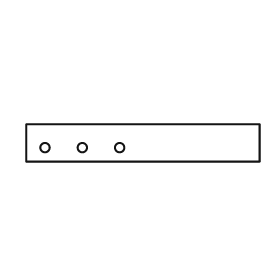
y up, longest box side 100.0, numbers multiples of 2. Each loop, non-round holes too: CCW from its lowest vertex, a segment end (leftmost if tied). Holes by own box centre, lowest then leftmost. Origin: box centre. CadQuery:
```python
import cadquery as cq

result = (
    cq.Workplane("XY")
    .moveTo(-50.0, -8.0)
    .lineTo(50.0, -8.0)
    .lineTo(50.0, 8.0)
    .lineTo(-50.0, 8.0)
    .close()
    .moveTo(-42.0, -2.0)
    .circle(2.0)
    .moveTo(-26.0, -2.0)
    .circle(2.0)
    .moveTo(-10.0, -2.0)
    .circle(2.0)
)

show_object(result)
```